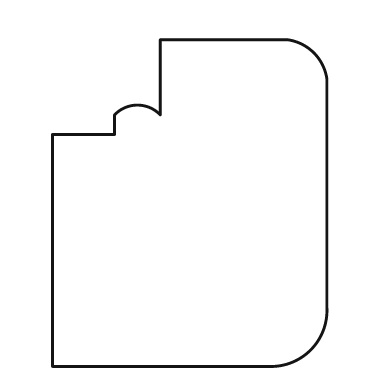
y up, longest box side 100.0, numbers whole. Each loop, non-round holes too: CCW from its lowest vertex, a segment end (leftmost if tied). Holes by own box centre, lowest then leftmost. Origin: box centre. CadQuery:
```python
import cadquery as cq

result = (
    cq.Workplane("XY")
    .moveTo(-42.0, -50.0)
    .lineTo(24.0, -50.0)
    .threePointArc((37.0, -45.0), (42.0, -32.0))
    .lineTo(42.0, 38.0)
    .threePointArc((38.0, 46.0), (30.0, 50.0))
    .lineTo(-9.0, 50.0)
    .lineTo(-9.0, 27.0)
    .threePointArc((-16.0, 30.0), (-23.0, 27.0))
    .lineTo(-23.0, 21.0)
    .lineTo(-42.0, 21.0)
    .close()
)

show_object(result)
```